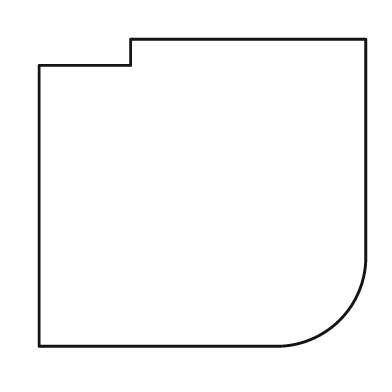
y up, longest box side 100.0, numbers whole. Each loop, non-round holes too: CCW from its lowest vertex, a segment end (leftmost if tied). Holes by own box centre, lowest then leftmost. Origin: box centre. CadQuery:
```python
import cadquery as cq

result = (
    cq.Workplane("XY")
    .moveTo(-50.0, -47.0)
    .lineTo(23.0, -47.0)
    .threePointArc((42.0, -39.0), (50.0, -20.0))
    .lineTo(50.0, 47.0)
    .lineTo(-22.0, 47.0)
    .lineTo(-22.0, 39.0)
    .lineTo(-50.0, 39.0)
    .close()
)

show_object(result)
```